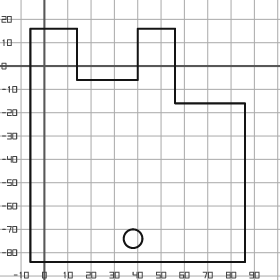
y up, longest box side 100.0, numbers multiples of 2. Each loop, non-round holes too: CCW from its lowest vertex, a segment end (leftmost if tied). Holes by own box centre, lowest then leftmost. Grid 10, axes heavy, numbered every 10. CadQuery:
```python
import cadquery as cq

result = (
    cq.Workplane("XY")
    .moveTo(-6.0, -84.0)
    .lineTo(86.0, -84.0)
    .lineTo(86.0, -16.0)
    .lineTo(56.0, -16.0)
    .lineTo(56.0, 16.0)
    .lineTo(40.0, 16.0)
    .lineTo(40.0, -6.0)
    .lineTo(14.0, -6.0)
    .lineTo(14.0, 16.0)
    .lineTo(-6.0, 16.0)
    .close()
    .moveTo(38.0, -74.0)
    .circle(4.0)
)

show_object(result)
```